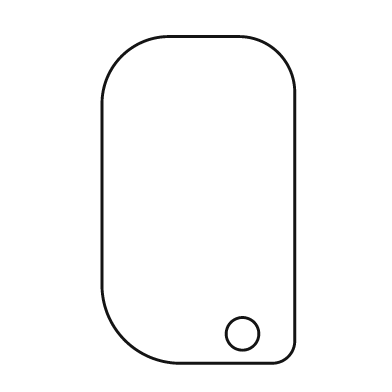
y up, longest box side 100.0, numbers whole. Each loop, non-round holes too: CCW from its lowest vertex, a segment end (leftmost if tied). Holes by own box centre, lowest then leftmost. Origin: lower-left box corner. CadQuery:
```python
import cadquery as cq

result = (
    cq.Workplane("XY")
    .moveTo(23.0, 0.0)
    .lineTo(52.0, 0.0)
    .threePointArc((57.0, 2.0), (59.0, 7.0))
    .lineTo(59.0, 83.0)
    .threePointArc((54.0, 95.0), (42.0, 100.0))
    .lineTo(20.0, 100.0)
    .threePointArc((6.0, 94.0), (0.0, 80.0))
    .lineTo(0.0, 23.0)
    .threePointArc((7.0, 7.0), (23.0, 0.0))
    .close()
    .moveTo(43.0, 9.0)
    .circle(5.0)
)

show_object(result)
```